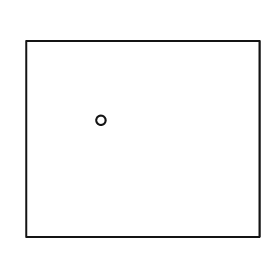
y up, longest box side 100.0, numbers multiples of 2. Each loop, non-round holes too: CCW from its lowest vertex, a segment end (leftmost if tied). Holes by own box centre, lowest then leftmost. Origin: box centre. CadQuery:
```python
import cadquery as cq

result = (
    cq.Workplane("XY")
    .moveTo(-50.0, -42.0)
    .lineTo(50.0, -42.0)
    .lineTo(50.0, 42.0)
    .lineTo(-50.0, 42.0)
    .close()
    .moveTo(-18.0, 8.0)
    .circle(2.0)
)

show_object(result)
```